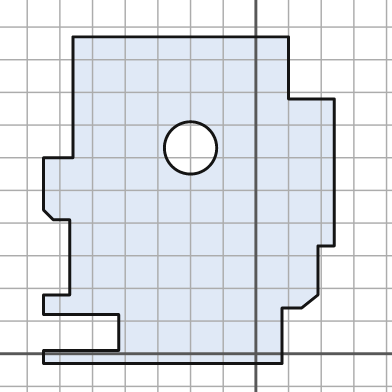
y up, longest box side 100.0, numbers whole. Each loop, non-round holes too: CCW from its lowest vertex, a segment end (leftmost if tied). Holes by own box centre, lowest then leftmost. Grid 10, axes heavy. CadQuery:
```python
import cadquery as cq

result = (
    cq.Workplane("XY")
    .moveTo(-65.0, -3.0)
    .lineTo(8.0, -3.0)
    .lineTo(8.0, 14.0)
    .lineTo(14.0, 14.0)
    .lineTo(19.0, 18.0)
    .lineTo(19.0, 33.0)
    .lineTo(24.0, 33.0)
    .lineTo(24.0, 78.0)
    .lineTo(10.0, 78.0)
    .lineTo(10.0, 97.0)
    .lineTo(-56.0, 97.0)
    .lineTo(-56.0, 60.0)
    .lineTo(-65.0, 60.0)
    .lineTo(-65.0, 44.0)
    .lineTo(-62.0, 41.0)
    .lineTo(-57.0, 41.0)
    .lineTo(-57.0, 18.0)
    .lineTo(-65.0, 18.0)
    .lineTo(-65.0, 12.0)
    .lineTo(-42.0, 12.0)
    .lineTo(-42.0, 1.0)
    .lineTo(-65.0, 1.0)
    .close()
    .moveTo(-20.0, 63.0)
    .circle(8.0)
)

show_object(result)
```